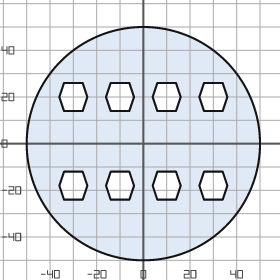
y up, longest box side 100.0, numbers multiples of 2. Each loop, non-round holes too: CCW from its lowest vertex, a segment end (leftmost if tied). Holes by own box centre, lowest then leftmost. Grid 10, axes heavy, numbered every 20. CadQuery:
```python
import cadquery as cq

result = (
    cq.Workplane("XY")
    .moveTo(0.0, 0.0)
    .circle(50.0)
    .moveTo(-34.0, -24.0)
    .lineTo(-26.0, -24.0)
    .lineTo(-24.0, -18.0)
    .lineTo(-26.0, -12.0)
    .lineTo(-34.0, -12.0)
    .lineTo(-36.0, -18.0)
    .close()
    .moveTo(-14.0, -24.0)
    .lineTo(-6.0, -24.0)
    .lineTo(-4.0, -18.0)
    .lineTo(-6.0, -12.0)
    .lineTo(-14.0, -12.0)
    .lineTo(-16.0, -18.0)
    .close()
    .moveTo(6.0, -24.0)
    .lineTo(14.0, -24.0)
    .lineTo(16.0, -18.0)
    .lineTo(14.0, -12.0)
    .lineTo(6.0, -12.0)
    .lineTo(4.0, -18.0)
    .close()
    .moveTo(26.0, -24.0)
    .lineTo(34.0, -24.0)
    .lineTo(36.0, -18.0)
    .lineTo(34.0, -12.0)
    .lineTo(26.0, -12.0)
    .lineTo(24.0, -18.0)
    .close()
    .moveTo(-34.0, 14.0)
    .lineTo(-26.0, 14.0)
    .lineTo(-24.0, 20.0)
    .lineTo(-26.0, 26.0)
    .lineTo(-34.0, 26.0)
    .lineTo(-36.0, 20.0)
    .close()
    .moveTo(-14.0, 14.0)
    .lineTo(-6.0, 14.0)
    .lineTo(-4.0, 20.0)
    .lineTo(-6.0, 26.0)
    .lineTo(-14.0, 26.0)
    .lineTo(-16.0, 20.0)
    .close()
    .moveTo(6.0, 14.0)
    .lineTo(14.0, 14.0)
    .lineTo(16.0, 20.0)
    .lineTo(14.0, 26.0)
    .lineTo(6.0, 26.0)
    .lineTo(4.0, 20.0)
    .close()
    .moveTo(26.0, 14.0)
    .lineTo(34.0, 14.0)
    .lineTo(36.0, 20.0)
    .lineTo(34.0, 26.0)
    .lineTo(26.0, 26.0)
    .lineTo(24.0, 20.0)
    .close()
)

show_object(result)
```